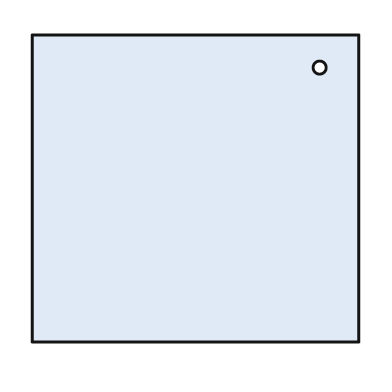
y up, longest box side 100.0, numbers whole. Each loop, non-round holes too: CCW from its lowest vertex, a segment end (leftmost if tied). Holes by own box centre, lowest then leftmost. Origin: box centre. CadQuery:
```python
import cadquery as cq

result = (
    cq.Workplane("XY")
    .moveTo(-50.0, -47.0)
    .lineTo(50.0, -47.0)
    .lineTo(50.0, 47.0)
    .lineTo(-50.0, 47.0)
    .close()
    .moveTo(38.0, 37.0)
    .circle(2.0)
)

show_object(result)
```